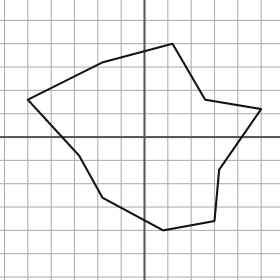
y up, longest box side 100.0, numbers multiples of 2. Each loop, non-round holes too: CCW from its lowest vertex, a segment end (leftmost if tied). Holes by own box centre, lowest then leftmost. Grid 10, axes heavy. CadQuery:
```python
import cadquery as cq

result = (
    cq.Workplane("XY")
    .moveTo(8.0, -40.0)
    .lineTo(30.0, -36.0)
    .lineTo(32.0, -14.0)
    .lineTo(50.0, 12.0)
    .lineTo(26.0, 16.0)
    .lineTo(12.0, 40.0)
    .lineTo(-18.0, 32.0)
    .lineTo(-50.0, 16.0)
    .lineTo(-28.0, -8.0)
    .lineTo(-18.0, -26.0)
    .close()
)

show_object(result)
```